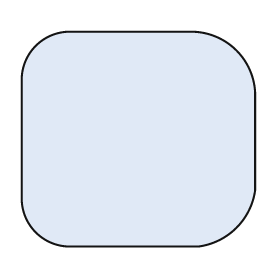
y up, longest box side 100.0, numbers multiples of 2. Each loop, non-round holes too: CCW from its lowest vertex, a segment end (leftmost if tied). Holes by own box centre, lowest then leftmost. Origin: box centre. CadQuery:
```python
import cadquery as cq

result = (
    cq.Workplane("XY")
    .moveTo(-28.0, -46.0)
    .lineTo(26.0, -46.0)
    .threePointArc((42.0, -38.0), (50.0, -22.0))
    .lineTo(50.0, 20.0)
    .threePointArc((42.0, 38.0), (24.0, 46.0))
    .lineTo(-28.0, 46.0)
    .threePointArc((-44.0, 40.0), (-50.0, 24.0))
    .lineTo(-50.0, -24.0)
    .threePointArc((-44.0, -40.0), (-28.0, -46.0))
    .close()
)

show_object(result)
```